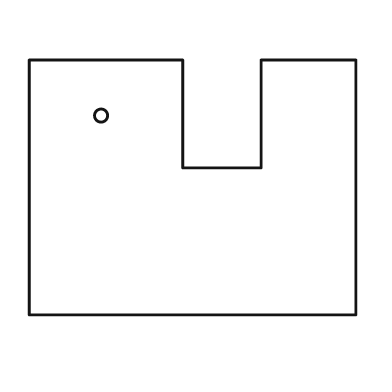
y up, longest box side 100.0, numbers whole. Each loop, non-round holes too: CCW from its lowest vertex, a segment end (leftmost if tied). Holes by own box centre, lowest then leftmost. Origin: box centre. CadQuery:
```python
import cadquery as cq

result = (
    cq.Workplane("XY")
    .moveTo(-50.0, -39.0)
    .lineTo(50.0, -39.0)
    .lineTo(50.0, 39.0)
    .lineTo(21.0, 39.0)
    .lineTo(21.0, 6.0)
    .lineTo(-3.0, 6.0)
    .lineTo(-3.0, 39.0)
    .lineTo(-50.0, 39.0)
    .close()
    .moveTo(-28.0, 22.0)
    .circle(2.0)
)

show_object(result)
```